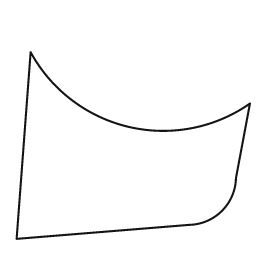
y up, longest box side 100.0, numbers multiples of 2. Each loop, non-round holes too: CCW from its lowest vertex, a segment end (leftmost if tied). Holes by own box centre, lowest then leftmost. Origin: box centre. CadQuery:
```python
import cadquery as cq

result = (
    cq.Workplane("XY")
    .moveTo(-50.0, -40.0)
    .lineTo(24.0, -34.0)
    .threePointArc((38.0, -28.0), (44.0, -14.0))
    .lineTo(50.0, 18.0)
    .threePointArc((-2.0, 8.0), (-44.0, 40.0))
    .close()
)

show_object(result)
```